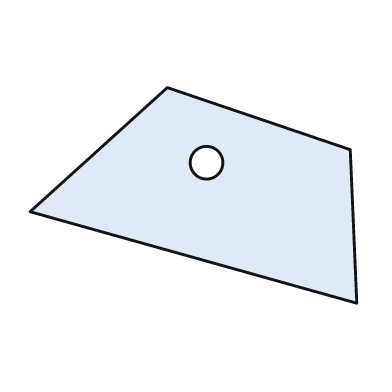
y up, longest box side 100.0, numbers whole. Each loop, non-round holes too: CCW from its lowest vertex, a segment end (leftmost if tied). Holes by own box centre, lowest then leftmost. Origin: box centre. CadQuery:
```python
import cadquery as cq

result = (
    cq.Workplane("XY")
    .moveTo(50.0, -33.0)
    .lineTo(48.0, 14.0)
    .lineTo(-8.0, 33.0)
    .lineTo(-50.0, -5.0)
    .close()
    .moveTo(4.0, 10.0)
    .circle(5.0)
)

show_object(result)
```